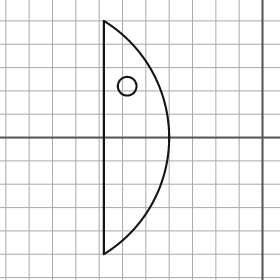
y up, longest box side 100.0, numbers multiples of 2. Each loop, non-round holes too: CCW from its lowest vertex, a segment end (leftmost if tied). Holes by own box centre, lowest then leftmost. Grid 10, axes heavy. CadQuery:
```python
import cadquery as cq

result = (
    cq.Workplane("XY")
    .moveTo(-68.0, -50.0)
    .threePointArc((-40.0, 0.0), (-68.0, 50.0))
    .close()
    .moveTo(-58.0, 22.0)
    .circle(4.0)
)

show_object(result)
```